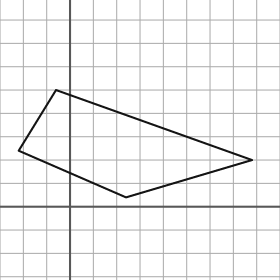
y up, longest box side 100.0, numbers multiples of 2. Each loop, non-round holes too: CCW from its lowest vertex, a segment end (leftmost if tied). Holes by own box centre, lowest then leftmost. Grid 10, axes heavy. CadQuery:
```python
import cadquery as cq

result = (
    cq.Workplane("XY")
    .moveTo(24.0, 4.0)
    .lineTo(78.0, 20.0)
    .lineTo(-6.0, 50.0)
    .lineTo(-22.0, 24.0)
    .close()
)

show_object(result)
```